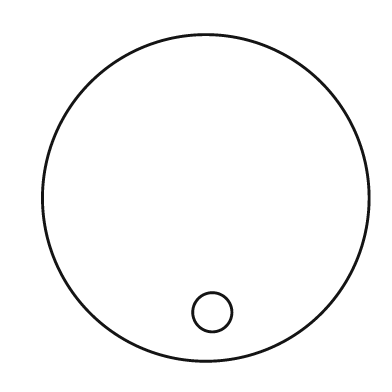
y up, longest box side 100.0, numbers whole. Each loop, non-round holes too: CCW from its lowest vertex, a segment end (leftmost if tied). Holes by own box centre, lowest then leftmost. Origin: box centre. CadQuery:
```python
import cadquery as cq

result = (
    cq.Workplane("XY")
    .moveTo(0.0, 0.0)
    .circle(50.0)
    .moveTo(2.0, -35.0)
    .circle(6.0)
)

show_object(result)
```